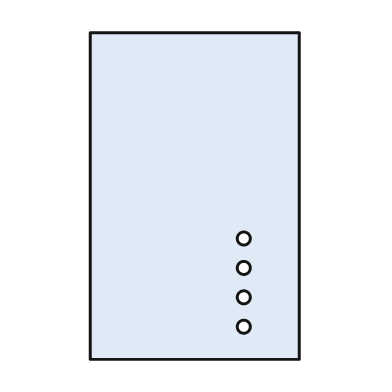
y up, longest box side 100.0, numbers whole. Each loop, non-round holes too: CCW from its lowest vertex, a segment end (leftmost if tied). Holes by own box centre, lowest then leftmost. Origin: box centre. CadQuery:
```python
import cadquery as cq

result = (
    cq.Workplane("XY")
    .moveTo(-32.0, -50.0)
    .lineTo(32.0, -50.0)
    .lineTo(32.0, 50.0)
    .lineTo(-32.0, 50.0)
    .close()
    .moveTo(15.0, -40.0)
    .circle(2.0)
    .moveTo(15.0, -31.0)
    .circle(2.0)
    .moveTo(15.0, -22.0)
    .circle(2.0)
    .moveTo(15.0, -13.0)
    .circle(2.0)
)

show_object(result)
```